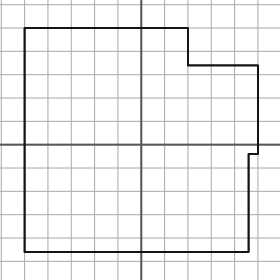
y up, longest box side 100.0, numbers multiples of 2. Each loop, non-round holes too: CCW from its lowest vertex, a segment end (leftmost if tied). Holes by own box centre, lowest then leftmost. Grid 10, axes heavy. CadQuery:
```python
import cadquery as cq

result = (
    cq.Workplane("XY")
    .moveTo(-50.0, -46.0)
    .lineTo(46.0, -46.0)
    .lineTo(46.0, -4.0)
    .lineTo(50.0, -4.0)
    .lineTo(50.0, 34.0)
    .lineTo(20.0, 34.0)
    .lineTo(20.0, 50.0)
    .lineTo(-50.0, 50.0)
    .close()
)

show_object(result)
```